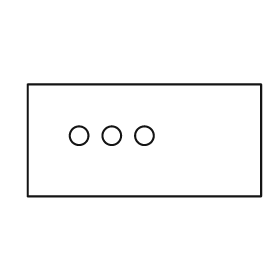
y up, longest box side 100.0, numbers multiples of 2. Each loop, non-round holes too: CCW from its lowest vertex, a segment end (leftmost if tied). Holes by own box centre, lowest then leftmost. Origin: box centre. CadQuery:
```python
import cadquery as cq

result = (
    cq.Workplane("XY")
    .moveTo(-50.0, -24.0)
    .lineTo(50.0, -24.0)
    .lineTo(50.0, 24.0)
    .lineTo(-50.0, 24.0)
    .close()
    .moveTo(-28.0, 2.0)
    .circle(4.0)
    .moveTo(-14.0, 2.0)
    .circle(4.0)
    .moveTo(0.0, 2.0)
    .circle(4.0)
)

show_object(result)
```